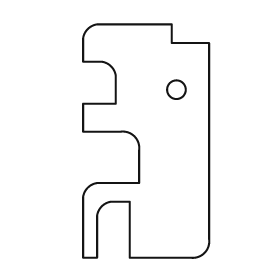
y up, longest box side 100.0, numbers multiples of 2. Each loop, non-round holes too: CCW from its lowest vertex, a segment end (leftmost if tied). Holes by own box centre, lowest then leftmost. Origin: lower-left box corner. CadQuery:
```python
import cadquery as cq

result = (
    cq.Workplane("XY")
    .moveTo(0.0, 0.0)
    .lineTo(6.0, 0.0)
    .lineTo(6.0, 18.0)
    .threePointArc((8.0, 22.0), (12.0, 24.0))
    .lineTo(20.0, 24.0)
    .lineTo(20.0, 0.0)
    .lineTo(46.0, 0.0)
    .threePointArc((52.0, 2.0), (54.0, 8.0))
    .lineTo(54.0, 92.0)
    .lineTo(38.0, 92.0)
    .lineTo(38.0, 100.0)
    .lineTo(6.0, 100.0)
    .threePointArc((2.0, 98.0), (0.0, 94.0))
    .lineTo(0.0, 84.0)
    .lineTo(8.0, 84.0)
    .threePointArc((12.0, 82.0), (14.0, 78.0))
    .lineTo(14.0, 66.0)
    .lineTo(0.0, 66.0)
    .lineTo(0.0, 54.0)
    .lineTo(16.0, 54.0)
    .threePointArc((22.0, 52.0), (24.0, 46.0))
    .lineTo(24.0, 32.0)
    .lineTo(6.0, 32.0)
    .threePointArc((2.0, 30.0), (0.0, 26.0))
    .close()
    .moveTo(40.0, 72.0)
    .circle(4.0)
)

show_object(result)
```